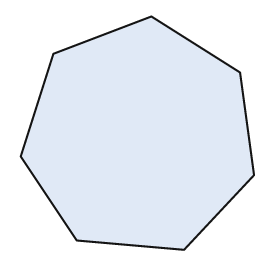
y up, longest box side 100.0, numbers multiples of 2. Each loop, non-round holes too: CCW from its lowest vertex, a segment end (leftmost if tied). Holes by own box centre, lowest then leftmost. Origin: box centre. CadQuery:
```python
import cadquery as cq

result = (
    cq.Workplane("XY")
    .moveTo(20.0, -50.0)
    .lineTo(50.0, -18.0)
    .lineTo(44.0, 26.0)
    .lineTo(6.0, 50.0)
    .lineTo(-36.0, 34.0)
    .lineTo(-50.0, -10.0)
    .lineTo(-26.0, -46.0)
    .close()
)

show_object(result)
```